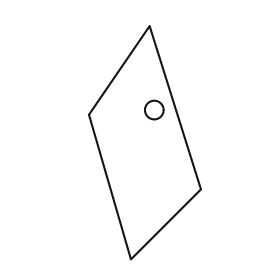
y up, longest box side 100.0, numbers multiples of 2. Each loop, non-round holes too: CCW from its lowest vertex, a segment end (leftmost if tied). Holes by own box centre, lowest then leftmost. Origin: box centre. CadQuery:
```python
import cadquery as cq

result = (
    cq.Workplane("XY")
    .moveTo(-6.0, -50.0)
    .lineTo(24.0, -20.0)
    .lineTo(2.0, 50.0)
    .lineTo(-24.0, 12.0)
    .close()
    .moveTo(4.0, 14.0)
    .circle(4.0)
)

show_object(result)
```